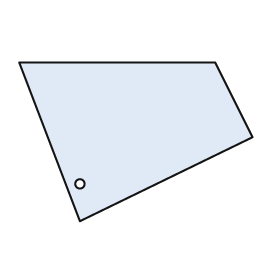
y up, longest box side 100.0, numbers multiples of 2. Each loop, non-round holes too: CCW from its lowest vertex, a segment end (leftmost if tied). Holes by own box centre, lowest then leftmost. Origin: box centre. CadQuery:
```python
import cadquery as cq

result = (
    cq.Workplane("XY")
    .moveTo(-24.0, -34.0)
    .lineTo(50.0, 2.0)
    .lineTo(34.0, 34.0)
    .lineTo(-50.0, 34.0)
    .close()
    .moveTo(-24.0, -18.0)
    .circle(2.0)
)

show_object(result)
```